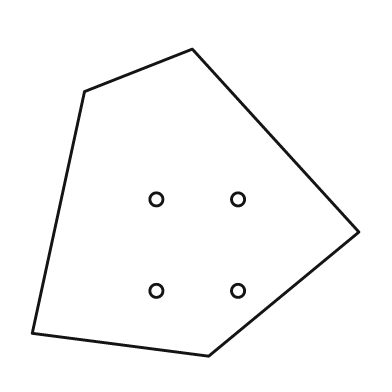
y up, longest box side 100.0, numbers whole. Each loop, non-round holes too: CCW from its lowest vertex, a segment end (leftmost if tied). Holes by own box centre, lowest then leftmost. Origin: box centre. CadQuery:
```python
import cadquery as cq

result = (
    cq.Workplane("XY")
    .moveTo(4.0, -47.0)
    .lineTo(50.0, -9.0)
    .lineTo(-1.0, 47.0)
    .lineTo(-34.0, 34.0)
    .lineTo(-50.0, -40.0)
    .close()
    .moveTo(-12.0, -27.0)
    .circle(2.0)
    .moveTo(13.0, -27.0)
    .circle(2.0)
    .moveTo(-12.0, 1.0)
    .circle(2.0)
    .moveTo(13.0, 1.0)
    .circle(2.0)
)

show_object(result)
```